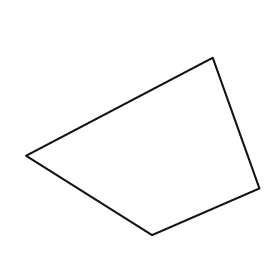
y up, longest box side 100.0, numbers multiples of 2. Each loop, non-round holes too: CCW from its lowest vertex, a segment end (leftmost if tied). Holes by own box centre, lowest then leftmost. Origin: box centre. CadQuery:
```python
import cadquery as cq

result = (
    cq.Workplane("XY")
    .moveTo(4.0, -38.0)
    .lineTo(50.0, -18.0)
    .lineTo(30.0, 38.0)
    .lineTo(-50.0, -4.0)
    .close()
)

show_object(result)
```